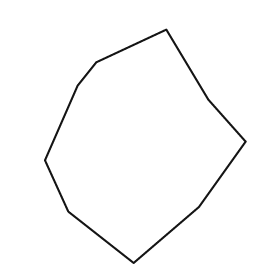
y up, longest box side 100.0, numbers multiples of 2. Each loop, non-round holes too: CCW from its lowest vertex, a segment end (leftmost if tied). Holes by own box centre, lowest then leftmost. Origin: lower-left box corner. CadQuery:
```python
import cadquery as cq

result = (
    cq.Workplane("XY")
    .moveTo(38.0, 0.0)
    .lineTo(66.0, 24.0)
    .lineTo(86.0, 52.0)
    .lineTo(70.0, 70.0)
    .lineTo(52.0, 100.0)
    .lineTo(22.0, 86.0)
    .lineTo(14.0, 76.0)
    .lineTo(0.0, 44.0)
    .lineTo(10.0, 22.0)
    .close()
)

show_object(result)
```